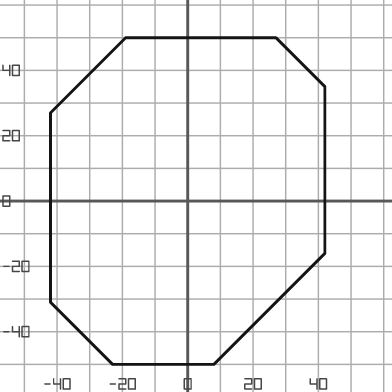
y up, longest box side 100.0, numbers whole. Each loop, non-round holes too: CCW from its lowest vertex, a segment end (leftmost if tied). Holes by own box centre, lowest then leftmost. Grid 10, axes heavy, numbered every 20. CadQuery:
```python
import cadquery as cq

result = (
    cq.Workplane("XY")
    .moveTo(-23.0, -50.0)
    .lineTo(8.0, -50.0)
    .lineTo(42.0, -16.0)
    .lineTo(42.0, 35.0)
    .lineTo(27.0, 50.0)
    .lineTo(-19.0, 50.0)
    .lineTo(-42.0, 27.0)
    .lineTo(-42.0, -31.0)
    .close()
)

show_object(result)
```